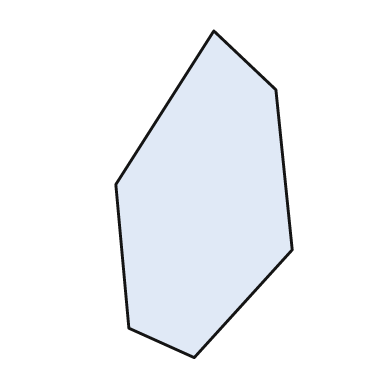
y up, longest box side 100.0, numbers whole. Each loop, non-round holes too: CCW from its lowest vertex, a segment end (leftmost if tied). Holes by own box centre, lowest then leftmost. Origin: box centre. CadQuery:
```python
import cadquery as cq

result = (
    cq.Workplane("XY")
    .moveTo(-3.0, -50.0)
    .lineTo(27.0, -17.0)
    .lineTo(22.0, 32.0)
    .lineTo(3.0, 50.0)
    .lineTo(-27.0, 3.0)
    .lineTo(-23.0, -41.0)
    .close()
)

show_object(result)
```